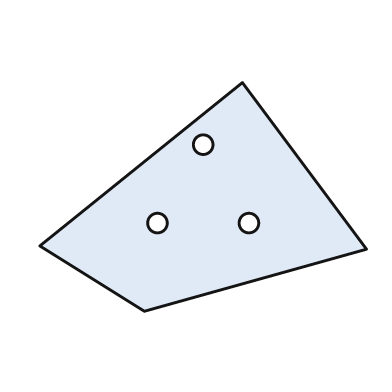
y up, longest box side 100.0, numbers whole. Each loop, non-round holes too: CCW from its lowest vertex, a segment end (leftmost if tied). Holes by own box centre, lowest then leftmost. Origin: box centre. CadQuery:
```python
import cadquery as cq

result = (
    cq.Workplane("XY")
    .moveTo(-18.0, -35.0)
    .lineTo(50.0, -16.0)
    .lineTo(12.0, 35.0)
    .lineTo(-50.0, -15.0)
    .close()
    .moveTo(-14.0, -8.0)
    .circle(3.0)
    .moveTo(14.0, -8.0)
    .circle(3.0)
    .moveTo(0.0, 16.0)
    .circle(3.0)
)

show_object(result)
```